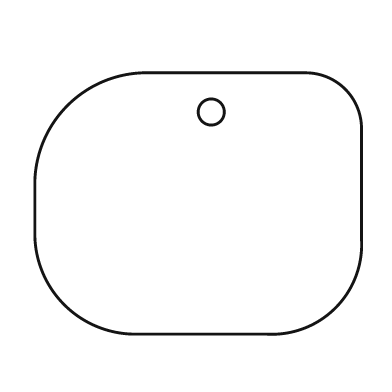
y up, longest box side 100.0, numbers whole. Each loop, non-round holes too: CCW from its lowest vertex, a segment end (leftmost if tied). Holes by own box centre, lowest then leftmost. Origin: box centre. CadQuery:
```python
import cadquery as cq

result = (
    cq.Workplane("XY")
    .moveTo(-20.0, -40.0)
    .lineTo(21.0, -40.0)
    .threePointArc((42.0, -32.0), (50.0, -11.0))
    .lineTo(50.0, 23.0)
    .threePointArc((45.0, 35.0), (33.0, 40.0))
    .lineTo(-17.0, 40.0)
    .threePointArc((-40.0, 30.0), (-50.0, 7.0))
    .lineTo(-50.0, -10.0)
    .threePointArc((-41.0, -31.0), (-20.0, -40.0))
    .close()
    .moveTo(4.0, 28.0)
    .circle(4.0)
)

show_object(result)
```